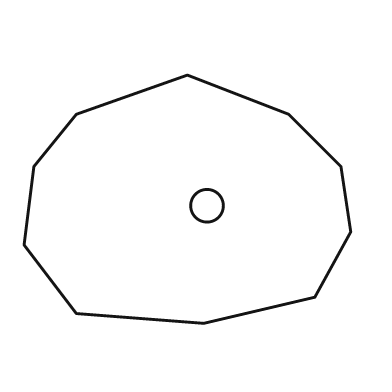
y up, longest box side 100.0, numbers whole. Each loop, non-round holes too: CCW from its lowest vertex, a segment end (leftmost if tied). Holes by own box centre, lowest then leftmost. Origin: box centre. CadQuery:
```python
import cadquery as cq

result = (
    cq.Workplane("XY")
    .moveTo(5.0, -38.0)
    .lineTo(39.0, -30.0)
    .lineTo(50.0, -10.0)
    .lineTo(47.0, 10.0)
    .lineTo(31.0, 26.0)
    .lineTo(0.0, 38.0)
    .lineTo(-34.0, 26.0)
    .lineTo(-47.0, 10.0)
    .lineTo(-50.0, -14.0)
    .lineTo(-34.0, -35.0)
    .close()
    .moveTo(6.0, -2.0)
    .circle(5.0)
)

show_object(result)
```